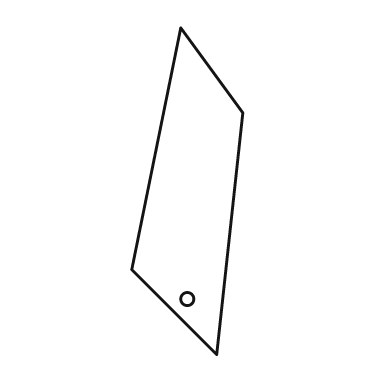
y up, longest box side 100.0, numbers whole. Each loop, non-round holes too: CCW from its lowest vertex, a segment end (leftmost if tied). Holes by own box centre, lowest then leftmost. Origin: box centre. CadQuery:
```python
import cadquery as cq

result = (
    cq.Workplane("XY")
    .moveTo(9.0, -50.0)
    .lineTo(17.0, 24.0)
    .lineTo(-2.0, 50.0)
    .lineTo(-17.0, -24.0)
    .close()
    .moveTo(0.0, -33.0)
    .circle(2.0)
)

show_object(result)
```